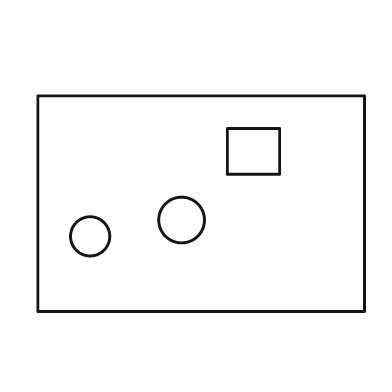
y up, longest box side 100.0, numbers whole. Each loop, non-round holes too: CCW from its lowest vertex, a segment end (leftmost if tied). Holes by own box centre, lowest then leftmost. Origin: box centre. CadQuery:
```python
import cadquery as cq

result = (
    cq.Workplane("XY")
    .moveTo(-50.0, -33.0)
    .lineTo(50.0, -33.0)
    .lineTo(50.0, 33.0)
    .lineTo(-50.0, 33.0)
    .close()
    .moveTo(-34.0, -10.0)
    .circle(6.0)
    .moveTo(-6.0, -5.0)
    .circle(7.0)
    .moveTo(8.0, 9.0)
    .lineTo(24.0, 9.0)
    .lineTo(24.0, 23.0)
    .lineTo(8.0, 23.0)
    .close()
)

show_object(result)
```